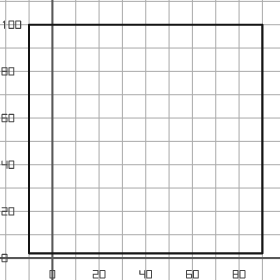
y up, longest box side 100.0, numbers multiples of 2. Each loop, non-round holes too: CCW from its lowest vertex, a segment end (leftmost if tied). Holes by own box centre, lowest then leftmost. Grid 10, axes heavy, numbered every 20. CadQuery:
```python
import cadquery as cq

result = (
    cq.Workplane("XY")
    .moveTo(-10.0, 2.0)
    .lineTo(90.0, 2.0)
    .lineTo(90.0, 100.0)
    .lineTo(-10.0, 100.0)
    .close()
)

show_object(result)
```